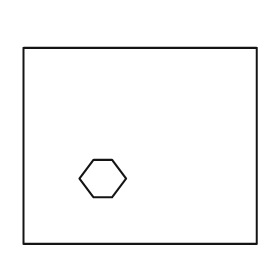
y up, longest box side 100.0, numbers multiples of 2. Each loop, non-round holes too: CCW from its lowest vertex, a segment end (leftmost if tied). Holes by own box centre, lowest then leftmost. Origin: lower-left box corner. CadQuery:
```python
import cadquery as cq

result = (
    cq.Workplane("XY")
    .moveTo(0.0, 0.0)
    .lineTo(100.0, 0.0)
    .lineTo(100.0, 84.0)
    .lineTo(0.0, 84.0)
    .close()
    .moveTo(30.0, 20.0)
    .lineTo(38.0, 20.0)
    .lineTo(44.0, 28.0)
    .lineTo(38.0, 36.0)
    .lineTo(30.0, 36.0)
    .lineTo(24.0, 28.0)
    .close()
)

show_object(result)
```